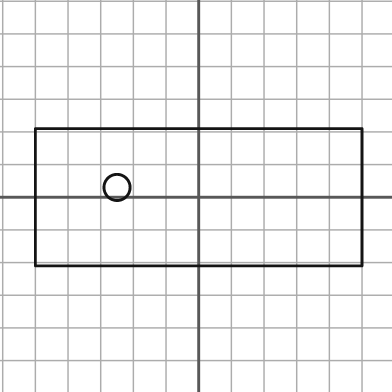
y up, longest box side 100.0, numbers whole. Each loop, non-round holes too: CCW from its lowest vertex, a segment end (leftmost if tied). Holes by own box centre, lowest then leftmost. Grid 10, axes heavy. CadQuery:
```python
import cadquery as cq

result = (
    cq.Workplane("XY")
    .moveTo(-50.0, -21.0)
    .lineTo(50.0, -21.0)
    .lineTo(50.0, 21.0)
    .lineTo(-50.0, 21.0)
    .close()
    .moveTo(-25.0, 3.0)
    .circle(4.0)
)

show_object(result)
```